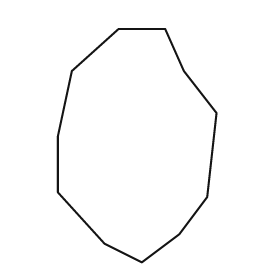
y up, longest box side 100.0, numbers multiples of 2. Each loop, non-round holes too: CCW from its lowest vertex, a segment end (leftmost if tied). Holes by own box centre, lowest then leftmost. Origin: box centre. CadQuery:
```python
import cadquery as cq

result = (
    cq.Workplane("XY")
    .moveTo(2.0, -50.0)
    .lineTo(18.0, -38.0)
    .lineTo(30.0, -22.0)
    .lineTo(34.0, 14.0)
    .lineTo(20.0, 32.0)
    .lineTo(12.0, 50.0)
    .lineTo(-8.0, 50.0)
    .lineTo(-28.0, 32.0)
    .lineTo(-34.0, 4.0)
    .lineTo(-34.0, -20.0)
    .lineTo(-14.0, -42.0)
    .close()
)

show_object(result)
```